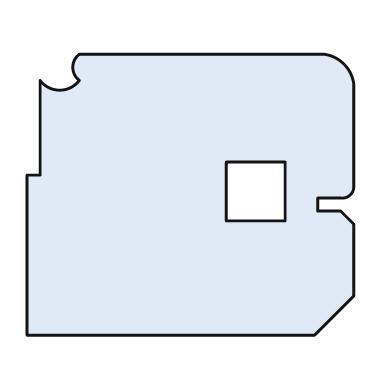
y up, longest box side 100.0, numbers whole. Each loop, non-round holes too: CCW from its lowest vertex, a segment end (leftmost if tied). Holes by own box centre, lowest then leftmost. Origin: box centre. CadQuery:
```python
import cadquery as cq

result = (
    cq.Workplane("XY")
    .moveTo(-50.0, -43.0)
    .lineTo(38.0, -43.0)
    .lineTo(50.0, -31.0)
    .lineTo(50.0, -9.0)
    .lineTo(46.0, -5.0)
    .lineTo(39.0, -5.0)
    .lineTo(39.0, -1.0)
    .lineTo(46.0, -1.0)
    .threePointArc((49.0, 0.0), (50.0, 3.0))
    .lineTo(50.0, 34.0)
    .threePointArc((47.0, 40.0), (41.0, 43.0))
    .lineTo(-34.0, 43.0)
    .threePointArc((-36.0, 39.0), (-34.0, 35.0))
    .threePointArc((-40.0, 32.0), (-46.0, 35.0))
    .lineTo(-46.0, 6.0)
    .lineTo(-50.0, 6.0)
    .close()
    .moveTo(11.0, -8.0)
    .lineTo(29.0, -8.0)
    .lineTo(29.0, 10.0)
    .lineTo(11.0, 10.0)
    .close()
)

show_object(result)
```